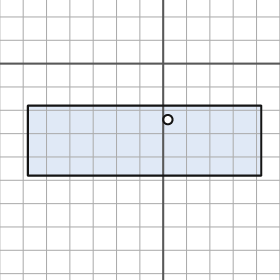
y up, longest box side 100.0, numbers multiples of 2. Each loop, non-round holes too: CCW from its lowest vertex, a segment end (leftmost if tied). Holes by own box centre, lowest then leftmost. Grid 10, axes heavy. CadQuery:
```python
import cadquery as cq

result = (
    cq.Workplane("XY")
    .moveTo(-58.0, -48.0)
    .lineTo(42.0, -48.0)
    .lineTo(42.0, -18.0)
    .lineTo(-58.0, -18.0)
    .close()
    .moveTo(2.0, -24.0)
    .circle(2.0)
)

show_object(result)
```